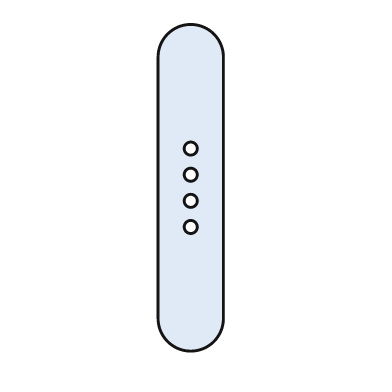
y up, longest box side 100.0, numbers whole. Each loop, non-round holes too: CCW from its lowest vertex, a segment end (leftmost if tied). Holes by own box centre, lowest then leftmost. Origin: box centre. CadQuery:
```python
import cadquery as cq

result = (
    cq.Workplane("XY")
    .moveTo(-10.0, -40.0)
    .threePointArc((0.0, -50.0), (10.0, -40.0))
    .lineTo(10.0, 40.0)
    .threePointArc((0.0, 50.0), (-10.0, 40.0))
    .close()
    .moveTo(0.0, -12.0)
    .circle(2.0)
    .moveTo(0.0, -4.0)
    .circle(2.0)
    .moveTo(0.0, 4.0)
    .circle(2.0)
    .moveTo(0.0, 12.0)
    .circle(2.0)
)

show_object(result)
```